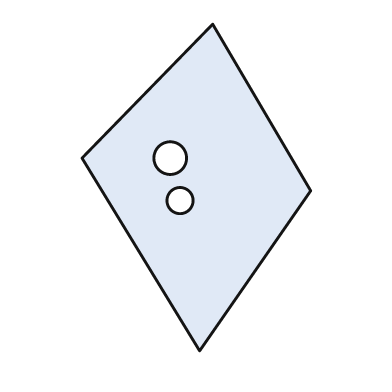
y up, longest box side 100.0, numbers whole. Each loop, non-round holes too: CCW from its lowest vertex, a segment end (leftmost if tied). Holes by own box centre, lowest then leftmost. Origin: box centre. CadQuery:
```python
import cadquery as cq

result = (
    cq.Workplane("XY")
    .moveTo(1.0, -50.0)
    .lineTo(35.0, -1.0)
    .lineTo(5.0, 50.0)
    .lineTo(-35.0, 9.0)
    .close()
    .moveTo(-5.0, -4.0)
    .circle(4.0)
    .moveTo(-8.0, 9.0)
    .circle(5.0)
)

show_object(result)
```